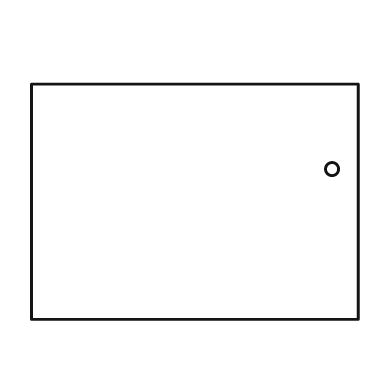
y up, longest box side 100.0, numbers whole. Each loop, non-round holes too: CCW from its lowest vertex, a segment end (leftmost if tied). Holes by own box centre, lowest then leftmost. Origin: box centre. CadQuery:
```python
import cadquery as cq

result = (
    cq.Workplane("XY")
    .moveTo(-50.0, -36.0)
    .lineTo(50.0, -36.0)
    .lineTo(50.0, 36.0)
    .lineTo(-50.0, 36.0)
    .close()
    .moveTo(42.0, 10.0)
    .circle(2.0)
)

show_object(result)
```